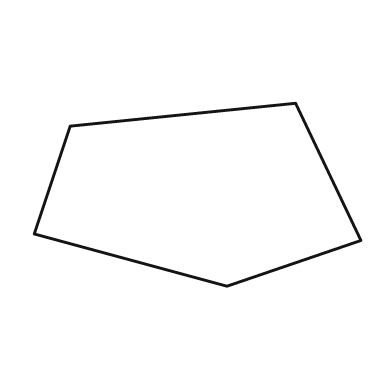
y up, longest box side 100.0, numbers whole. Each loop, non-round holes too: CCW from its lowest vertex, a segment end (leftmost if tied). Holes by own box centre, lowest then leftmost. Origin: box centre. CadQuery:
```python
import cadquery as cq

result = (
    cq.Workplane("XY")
    .moveTo(9.0, -28.0)
    .lineTo(50.0, -14.0)
    .lineTo(30.0, 28.0)
    .lineTo(-39.0, 21.0)
    .lineTo(-50.0, -12.0)
    .close()
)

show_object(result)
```